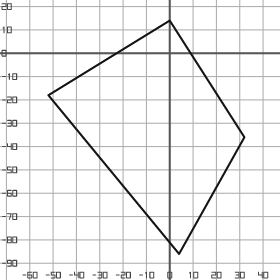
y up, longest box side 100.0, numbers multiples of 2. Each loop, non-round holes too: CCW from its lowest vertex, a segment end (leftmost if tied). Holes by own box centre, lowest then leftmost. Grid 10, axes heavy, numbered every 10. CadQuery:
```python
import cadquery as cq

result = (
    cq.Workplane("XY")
    .moveTo(4.0, -86.0)
    .lineTo(32.0, -36.0)
    .lineTo(0.0, 14.0)
    .lineTo(-52.0, -18.0)
    .close()
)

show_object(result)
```